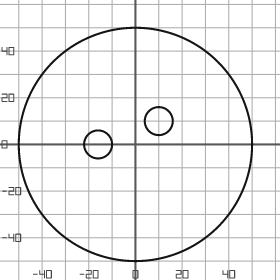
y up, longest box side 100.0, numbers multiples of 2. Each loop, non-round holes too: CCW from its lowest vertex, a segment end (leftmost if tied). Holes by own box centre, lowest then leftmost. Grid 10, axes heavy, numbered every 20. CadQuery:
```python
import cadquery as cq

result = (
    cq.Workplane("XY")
    .moveTo(0.0, 0.0)
    .circle(50.0)
    .moveTo(-16.0, 0.0)
    .circle(6.0)
    .moveTo(10.0, 10.0)
    .circle(6.0)
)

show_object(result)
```